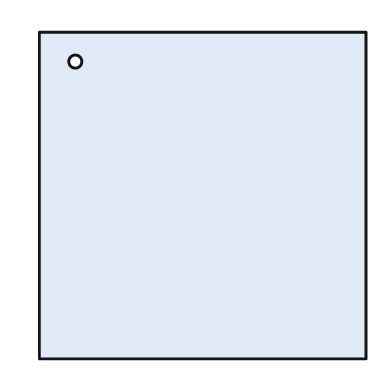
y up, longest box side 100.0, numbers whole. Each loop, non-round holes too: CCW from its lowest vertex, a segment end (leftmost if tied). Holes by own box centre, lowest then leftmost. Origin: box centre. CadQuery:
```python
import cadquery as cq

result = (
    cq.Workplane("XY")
    .moveTo(-50.0, -50.0)
    .lineTo(50.0, -50.0)
    .lineTo(50.0, 50.0)
    .lineTo(-50.0, 50.0)
    .close()
    .moveTo(-39.0, 41.0)
    .circle(2.0)
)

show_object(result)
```